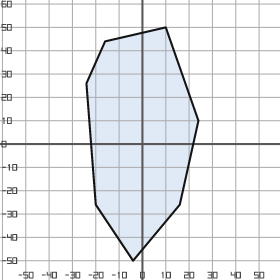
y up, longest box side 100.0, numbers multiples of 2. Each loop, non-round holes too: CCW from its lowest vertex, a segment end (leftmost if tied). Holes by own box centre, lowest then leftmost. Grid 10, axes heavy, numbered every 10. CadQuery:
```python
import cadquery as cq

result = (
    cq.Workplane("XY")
    .moveTo(-4.0, -50.0)
    .lineTo(16.0, -26.0)
    .lineTo(24.0, 10.0)
    .lineTo(10.0, 50.0)
    .lineTo(-16.0, 44.0)
    .lineTo(-24.0, 26.0)
    .lineTo(-20.0, -26.0)
    .close()
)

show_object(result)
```